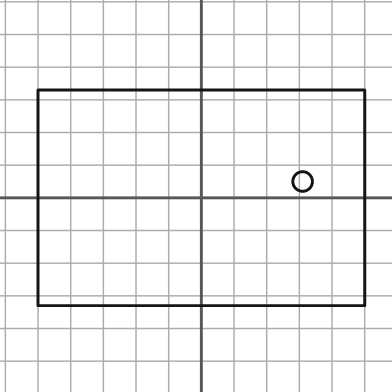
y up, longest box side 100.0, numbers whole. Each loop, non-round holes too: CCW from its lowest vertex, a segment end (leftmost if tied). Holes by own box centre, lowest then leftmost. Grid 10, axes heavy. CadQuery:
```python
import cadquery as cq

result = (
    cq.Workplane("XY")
    .moveTo(-50.0, -33.0)
    .lineTo(50.0, -33.0)
    .lineTo(50.0, 33.0)
    .lineTo(-50.0, 33.0)
    .close()
    .moveTo(31.0, 5.0)
    .circle(3.0)
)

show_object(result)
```